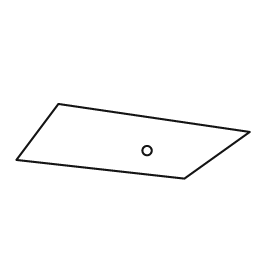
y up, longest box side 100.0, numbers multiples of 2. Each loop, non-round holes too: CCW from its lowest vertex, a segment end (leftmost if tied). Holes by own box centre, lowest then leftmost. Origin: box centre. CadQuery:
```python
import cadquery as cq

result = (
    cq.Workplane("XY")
    .moveTo(22.0, -16.0)
    .lineTo(50.0, 4.0)
    .lineTo(-32.0, 16.0)
    .lineTo(-50.0, -8.0)
    .close()
    .moveTo(6.0, -4.0)
    .circle(2.0)
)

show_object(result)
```